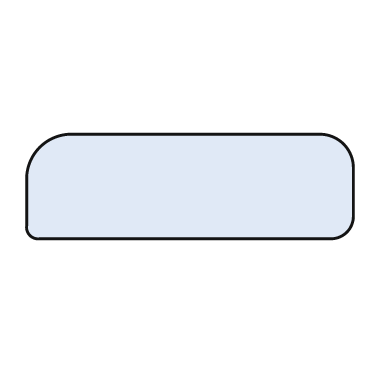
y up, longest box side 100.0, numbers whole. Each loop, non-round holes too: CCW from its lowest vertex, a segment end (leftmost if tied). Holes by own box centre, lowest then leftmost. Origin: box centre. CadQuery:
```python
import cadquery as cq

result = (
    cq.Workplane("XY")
    .moveTo(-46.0, -16.0)
    .lineTo(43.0, -16.0)
    .threePointArc((48.0, -14.0), (50.0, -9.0))
    .lineTo(50.0, 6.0)
    .threePointArc((47.0, 13.0), (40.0, 16.0))
    .lineTo(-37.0, 16.0)
    .threePointArc((-46.0, 12.0), (-50.0, 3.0))
    .lineTo(-50.0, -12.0)
    .threePointArc((-49.0, -15.0), (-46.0, -16.0))
    .close()
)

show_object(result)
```